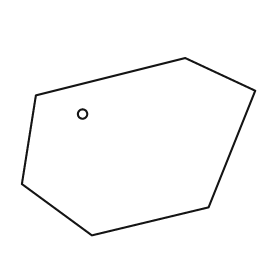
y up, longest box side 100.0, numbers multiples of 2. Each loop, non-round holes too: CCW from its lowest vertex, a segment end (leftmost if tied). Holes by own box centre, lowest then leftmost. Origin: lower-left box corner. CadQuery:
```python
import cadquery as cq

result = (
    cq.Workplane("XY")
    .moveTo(30.0, 0.0)
    .lineTo(80.0, 12.0)
    .lineTo(100.0, 62.0)
    .lineTo(70.0, 76.0)
    .lineTo(6.0, 60.0)
    .lineTo(0.0, 22.0)
    .close()
    .moveTo(26.0, 52.0)
    .circle(2.0)
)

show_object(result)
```